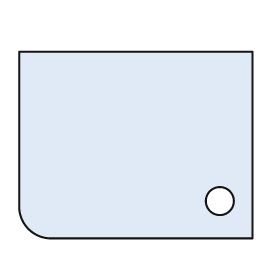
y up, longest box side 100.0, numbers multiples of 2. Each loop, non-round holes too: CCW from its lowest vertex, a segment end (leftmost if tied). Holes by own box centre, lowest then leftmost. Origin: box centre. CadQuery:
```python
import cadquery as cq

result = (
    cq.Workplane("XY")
    .moveTo(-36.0, -40.0)
    .lineTo(50.0, -40.0)
    .lineTo(50.0, 40.0)
    .lineTo(-50.0, 40.0)
    .lineTo(-50.0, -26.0)
    .threePointArc((-46.0, -36.0), (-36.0, -40.0))
    .close()
    .moveTo(36.0, -24.0)
    .circle(6.0)
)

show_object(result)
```